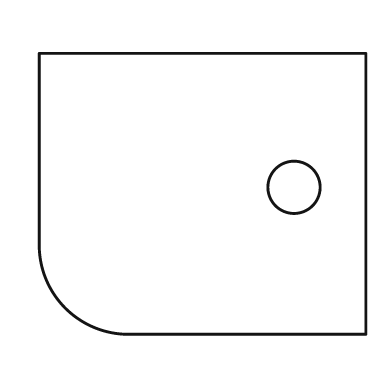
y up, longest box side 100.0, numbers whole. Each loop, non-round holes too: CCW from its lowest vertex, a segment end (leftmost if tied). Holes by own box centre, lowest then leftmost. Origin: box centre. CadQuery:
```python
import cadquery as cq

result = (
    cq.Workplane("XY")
    .moveTo(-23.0, -43.0)
    .lineTo(50.0, -43.0)
    .lineTo(50.0, 43.0)
    .lineTo(-50.0, 43.0)
    .lineTo(-50.0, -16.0)
    .threePointArc((-42.0, -35.0), (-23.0, -43.0))
    .close()
    .moveTo(28.0, 2.0)
    .circle(8.0)
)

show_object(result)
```